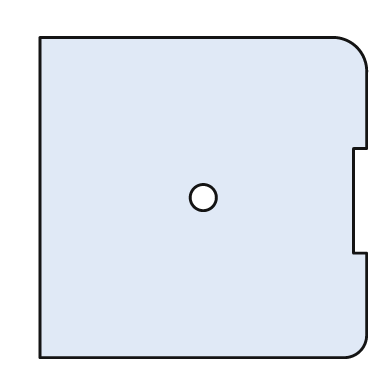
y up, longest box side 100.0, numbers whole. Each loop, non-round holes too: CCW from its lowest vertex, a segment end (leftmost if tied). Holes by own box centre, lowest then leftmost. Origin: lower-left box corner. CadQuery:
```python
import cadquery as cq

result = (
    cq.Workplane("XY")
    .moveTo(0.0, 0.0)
    .lineTo(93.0, 0.0)
    .threePointArc((98.0, 2.0), (100.0, 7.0))
    .lineTo(100.0, 32.0)
    .lineTo(96.0, 32.0)
    .lineTo(96.0, 64.0)
    .lineTo(100.0, 64.0)
    .lineTo(100.0, 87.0)
    .threePointArc((97.0, 95.0), (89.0, 98.0))
    .lineTo(0.0, 98.0)
    .close()
    .moveTo(50.0, 49.0)
    .circle(4.0)
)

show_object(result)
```